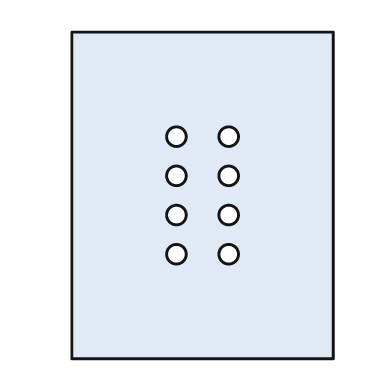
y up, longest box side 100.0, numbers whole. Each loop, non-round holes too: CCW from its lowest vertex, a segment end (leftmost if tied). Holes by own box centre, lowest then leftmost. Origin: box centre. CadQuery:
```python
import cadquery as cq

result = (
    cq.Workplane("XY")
    .moveTo(-40.0, -50.0)
    .lineTo(40.0, -50.0)
    .lineTo(40.0, 50.0)
    .lineTo(-40.0, 50.0)
    .close()
    .moveTo(-8.0, -18.0)
    .circle(3.0)
    .moveTo(8.0, -18.0)
    .circle(3.0)
    .moveTo(-8.0, -6.0)
    .circle(3.0)
    .moveTo(8.0, -6.0)
    .circle(3.0)
    .moveTo(-8.0, 6.0)
    .circle(3.0)
    .moveTo(8.0, 6.0)
    .circle(3.0)
    .moveTo(-8.0, 18.0)
    .circle(3.0)
    .moveTo(8.0, 18.0)
    .circle(3.0)
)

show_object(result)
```